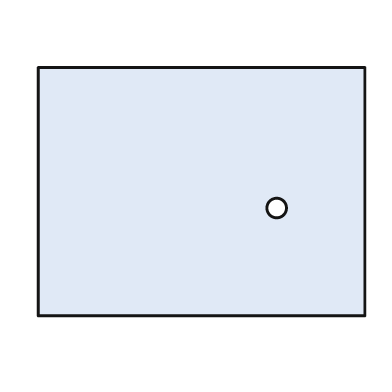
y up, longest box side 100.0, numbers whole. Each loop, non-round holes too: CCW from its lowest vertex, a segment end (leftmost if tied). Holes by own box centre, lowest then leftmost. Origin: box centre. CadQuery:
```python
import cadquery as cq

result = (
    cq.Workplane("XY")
    .moveTo(-50.0, -38.0)
    .lineTo(50.0, -38.0)
    .lineTo(50.0, 38.0)
    .lineTo(-50.0, 38.0)
    .close()
    .moveTo(23.0, -5.0)
    .circle(3.0)
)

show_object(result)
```